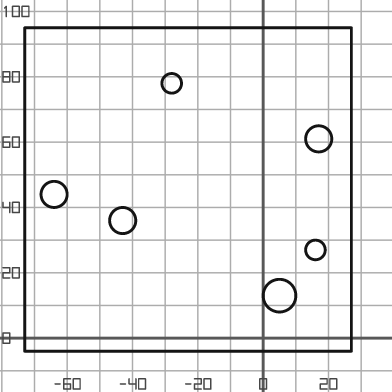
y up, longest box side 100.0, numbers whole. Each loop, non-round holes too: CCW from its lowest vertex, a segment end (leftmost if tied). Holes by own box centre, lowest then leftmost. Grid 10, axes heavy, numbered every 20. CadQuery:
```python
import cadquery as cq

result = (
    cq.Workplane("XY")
    .moveTo(-73.0, -4.0)
    .lineTo(27.0, -4.0)
    .lineTo(27.0, 95.0)
    .lineTo(-73.0, 95.0)
    .close()
    .moveTo(5.0, 13.0)
    .circle(5.0)
    .moveTo(16.0, 27.0)
    .circle(3.0)
    .moveTo(-43.0, 36.0)
    .circle(4.0)
    .moveTo(-64.0, 44.0)
    .circle(4.0)
    .moveTo(17.0, 61.0)
    .circle(4.0)
    .moveTo(-28.0, 78.0)
    .circle(3.0)
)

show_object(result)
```